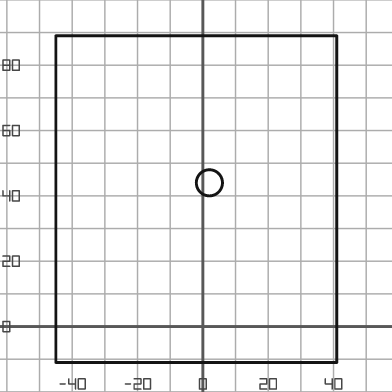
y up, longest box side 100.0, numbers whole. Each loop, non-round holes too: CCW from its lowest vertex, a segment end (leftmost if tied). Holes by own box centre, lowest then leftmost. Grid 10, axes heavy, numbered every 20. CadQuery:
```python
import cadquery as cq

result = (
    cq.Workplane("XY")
    .moveTo(-45.0, -11.0)
    .lineTo(41.0, -11.0)
    .lineTo(41.0, 89.0)
    .lineTo(-45.0, 89.0)
    .close()
    .moveTo(2.0, 44.0)
    .circle(4.0)
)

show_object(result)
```